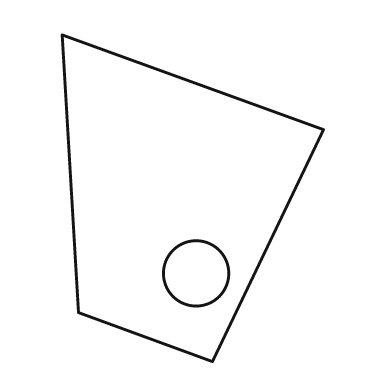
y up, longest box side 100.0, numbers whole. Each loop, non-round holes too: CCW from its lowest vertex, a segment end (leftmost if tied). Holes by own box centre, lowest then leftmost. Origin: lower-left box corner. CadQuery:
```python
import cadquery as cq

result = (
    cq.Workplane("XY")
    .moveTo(46.0, 0.0)
    .lineTo(80.0, 71.0)
    .lineTo(0.0, 100.0)
    .lineTo(5.0, 15.0)
    .close()
    .moveTo(41.0, 27.0)
    .circle(10.0)
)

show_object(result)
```